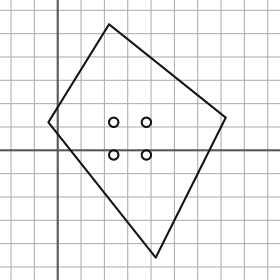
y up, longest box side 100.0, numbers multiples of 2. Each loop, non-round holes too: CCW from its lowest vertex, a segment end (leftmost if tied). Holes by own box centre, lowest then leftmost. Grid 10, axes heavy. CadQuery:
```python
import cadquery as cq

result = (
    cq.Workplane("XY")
    .moveTo(42.0, -46.0)
    .lineTo(72.0, 14.0)
    .lineTo(22.0, 54.0)
    .lineTo(-4.0, 12.0)
    .close()
    .moveTo(24.0, -2.0)
    .circle(2.0)
    .moveTo(38.0, -2.0)
    .circle(2.0)
    .moveTo(24.0, 12.0)
    .circle(2.0)
    .moveTo(38.0, 12.0)
    .circle(2.0)
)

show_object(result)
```